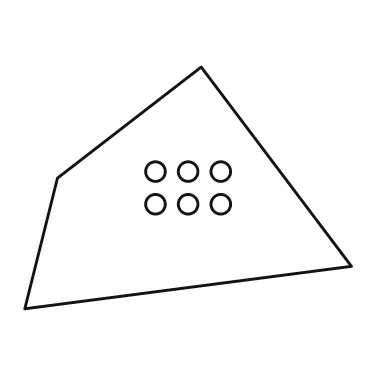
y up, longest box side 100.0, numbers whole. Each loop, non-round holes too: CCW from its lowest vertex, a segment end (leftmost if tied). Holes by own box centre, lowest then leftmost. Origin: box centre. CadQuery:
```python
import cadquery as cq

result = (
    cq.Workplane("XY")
    .moveTo(-50.0, -37.0)
    .lineTo(50.0, -24.0)
    .lineTo(4.0, 37.0)
    .lineTo(-40.0, 3.0)
    .close()
    .moveTo(-10.0, -5.0)
    .circle(3.0)
    .moveTo(0.0, -5.0)
    .circle(3.0)
    .moveTo(10.0, -5.0)
    .circle(3.0)
    .moveTo(-10.0, 5.0)
    .circle(3.0)
    .moveTo(0.0, 5.0)
    .circle(3.0)
    .moveTo(10.0, 5.0)
    .circle(3.0)
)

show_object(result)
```